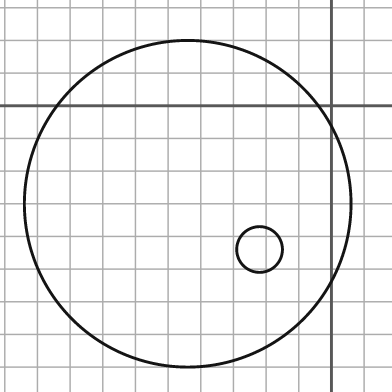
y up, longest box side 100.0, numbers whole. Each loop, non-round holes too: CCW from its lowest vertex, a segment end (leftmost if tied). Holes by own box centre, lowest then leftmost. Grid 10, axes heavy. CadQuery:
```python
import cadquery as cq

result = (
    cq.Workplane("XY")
    .moveTo(-44.0, -30.0)
    .circle(50.0)
    .moveTo(-22.0, -44.0)
    .circle(7.0)
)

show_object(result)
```